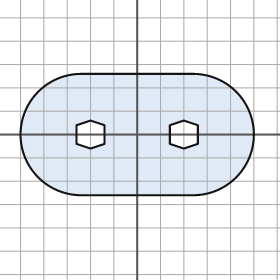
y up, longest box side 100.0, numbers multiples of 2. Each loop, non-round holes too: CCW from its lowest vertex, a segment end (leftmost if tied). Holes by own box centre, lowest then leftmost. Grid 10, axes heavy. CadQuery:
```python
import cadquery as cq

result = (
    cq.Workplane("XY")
    .moveTo(-24.0, -26.0)
    .lineTo(24.0, -26.0)
    .threePointArc((50.0, 0.0), (24.0, 26.0))
    .lineTo(-24.0, 26.0)
    .threePointArc((-50.0, 0.0), (-24.0, -26.0))
    .close()
    .moveTo(-20.0, -6.0)
    .lineTo(-14.0, -4.0)
    .lineTo(-14.0, 4.0)
    .lineTo(-20.0, 6.0)
    .lineTo(-26.0, 4.0)
    .lineTo(-26.0, -4.0)
    .close()
    .moveTo(20.0, -6.0)
    .lineTo(26.0, -4.0)
    .lineTo(26.0, 4.0)
    .lineTo(20.0, 6.0)
    .lineTo(14.0, 4.0)
    .lineTo(14.0, -4.0)
    .close()
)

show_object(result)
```